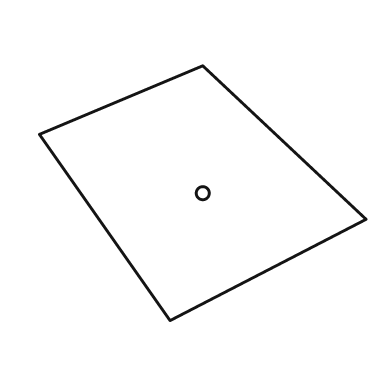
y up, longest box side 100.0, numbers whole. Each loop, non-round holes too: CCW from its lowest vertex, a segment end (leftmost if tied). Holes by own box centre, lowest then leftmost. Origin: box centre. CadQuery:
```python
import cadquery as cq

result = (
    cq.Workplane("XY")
    .moveTo(-10.0, -39.0)
    .lineTo(50.0, -8.0)
    .lineTo(0.0, 39.0)
    .lineTo(-50.0, 18.0)
    .close()
    .moveTo(0.0, 0.0)
    .circle(2.0)
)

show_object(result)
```